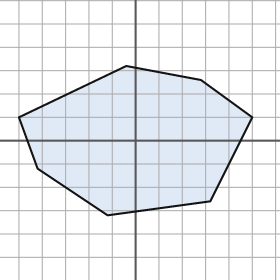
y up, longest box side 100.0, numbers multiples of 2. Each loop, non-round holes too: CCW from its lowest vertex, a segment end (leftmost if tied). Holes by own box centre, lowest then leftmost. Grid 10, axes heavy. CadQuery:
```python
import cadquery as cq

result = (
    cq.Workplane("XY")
    .moveTo(-12.0, -32.0)
    .lineTo(32.0, -26.0)
    .lineTo(50.0, 10.0)
    .lineTo(28.0, 26.0)
    .lineTo(-4.0, 32.0)
    .lineTo(-50.0, 10.0)
    .lineTo(-42.0, -12.0)
    .close()
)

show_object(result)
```